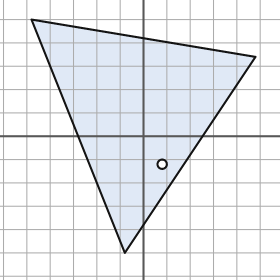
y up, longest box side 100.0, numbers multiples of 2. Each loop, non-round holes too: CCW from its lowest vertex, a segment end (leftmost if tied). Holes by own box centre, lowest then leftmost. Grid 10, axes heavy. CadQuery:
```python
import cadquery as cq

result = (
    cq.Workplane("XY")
    .moveTo(-8.0, -50.0)
    .lineTo(48.0, 34.0)
    .lineTo(-48.0, 50.0)
    .close()
    .moveTo(8.0, -12.0)
    .circle(2.0)
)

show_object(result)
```